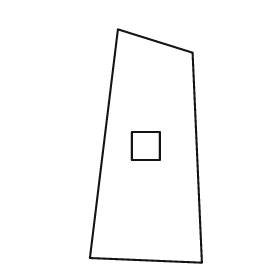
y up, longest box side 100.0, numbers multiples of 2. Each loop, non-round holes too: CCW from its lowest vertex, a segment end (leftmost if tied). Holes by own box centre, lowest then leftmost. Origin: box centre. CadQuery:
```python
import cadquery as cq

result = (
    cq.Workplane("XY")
    .moveTo(24.0, -50.0)
    .lineTo(20.0, 40.0)
    .lineTo(-12.0, 50.0)
    .lineTo(-24.0, -48.0)
    .close()
    .moveTo(-6.0, -6.0)
    .lineTo(6.0, -6.0)
    .lineTo(6.0, 6.0)
    .lineTo(-6.0, 6.0)
    .close()
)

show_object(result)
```